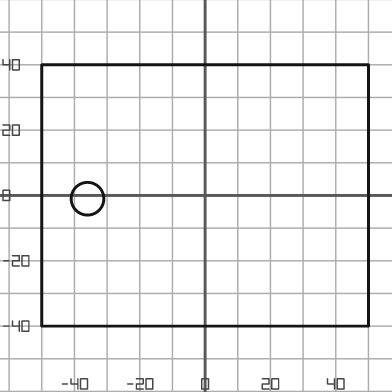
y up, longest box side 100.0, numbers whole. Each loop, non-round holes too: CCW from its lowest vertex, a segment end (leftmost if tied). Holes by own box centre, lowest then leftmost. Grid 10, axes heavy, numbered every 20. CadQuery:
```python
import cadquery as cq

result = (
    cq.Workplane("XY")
    .moveTo(-50.0, -40.0)
    .lineTo(50.0, -40.0)
    .lineTo(50.0, 40.0)
    .lineTo(-50.0, 40.0)
    .close()
    .moveTo(-36.0, -1.0)
    .circle(5.0)
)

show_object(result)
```